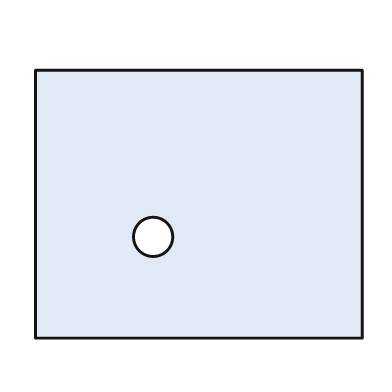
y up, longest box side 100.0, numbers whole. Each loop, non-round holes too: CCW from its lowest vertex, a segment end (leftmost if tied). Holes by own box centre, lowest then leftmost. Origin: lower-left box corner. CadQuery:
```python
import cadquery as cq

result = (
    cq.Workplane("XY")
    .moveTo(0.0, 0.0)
    .lineTo(100.0, 0.0)
    .lineTo(100.0, 82.0)
    .lineTo(0.0, 82.0)
    .close()
    .moveTo(36.0, 31.0)
    .circle(6.0)
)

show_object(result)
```